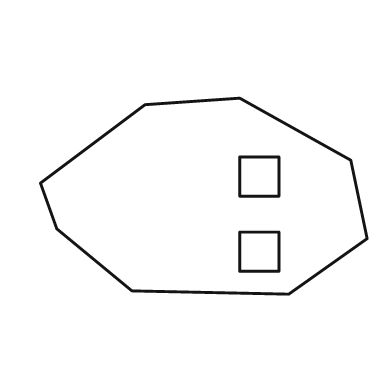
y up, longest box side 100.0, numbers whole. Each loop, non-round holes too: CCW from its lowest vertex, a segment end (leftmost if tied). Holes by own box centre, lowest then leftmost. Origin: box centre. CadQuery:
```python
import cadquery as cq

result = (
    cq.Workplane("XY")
    .moveTo(26.0, -30.0)
    .lineTo(50.0, -13.0)
    .lineTo(45.0, 11.0)
    .lineTo(11.0, 30.0)
    .lineTo(-18.0, 28.0)
    .lineTo(-50.0, 4.0)
    .lineTo(-45.0, -10.0)
    .lineTo(-22.0, -29.0)
    .close()
    .moveTo(11.0, -23.0)
    .lineTo(23.0, -23.0)
    .lineTo(23.0, -11.0)
    .lineTo(11.0, -11.0)
    .close()
    .moveTo(11.0, 0.0)
    .lineTo(23.0, 0.0)
    .lineTo(23.0, 12.0)
    .lineTo(11.0, 12.0)
    .close()
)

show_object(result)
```